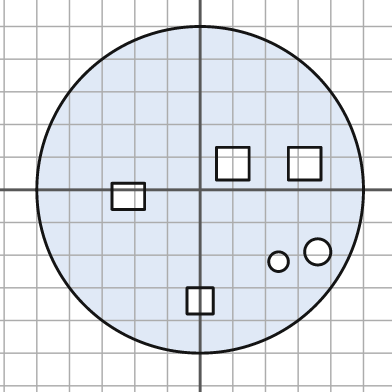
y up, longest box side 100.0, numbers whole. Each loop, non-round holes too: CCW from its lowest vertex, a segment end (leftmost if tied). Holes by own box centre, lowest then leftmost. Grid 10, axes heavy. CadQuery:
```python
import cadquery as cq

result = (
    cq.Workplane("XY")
    .moveTo(0.0, 0.0)
    .circle(50.0)
    .moveTo(-4.0, -38.0)
    .lineTo(4.0, -38.0)
    .lineTo(4.0, -30.0)
    .lineTo(-4.0, -30.0)
    .close()
    .moveTo(24.0, -22.0)
    .circle(3.0)
    .moveTo(36.0, -19.0)
    .circle(4.0)
    .moveTo(-27.0, -6.0)
    .lineTo(-17.0, -6.0)
    .lineTo(-17.0, 2.0)
    .lineTo(-27.0, 2.0)
    .close()
    .moveTo(5.0, 3.0)
    .lineTo(15.0, 3.0)
    .lineTo(15.0, 13.0)
    .lineTo(5.0, 13.0)
    .close()
    .moveTo(27.0, 3.0)
    .lineTo(37.0, 3.0)
    .lineTo(37.0, 13.0)
    .lineTo(27.0, 13.0)
    .close()
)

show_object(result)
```